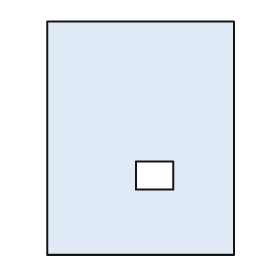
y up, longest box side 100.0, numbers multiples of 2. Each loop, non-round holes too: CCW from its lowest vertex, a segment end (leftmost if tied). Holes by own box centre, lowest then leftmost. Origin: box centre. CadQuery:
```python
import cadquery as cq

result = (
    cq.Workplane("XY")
    .moveTo(-40.0, -50.0)
    .lineTo(40.0, -50.0)
    .lineTo(40.0, 50.0)
    .lineTo(-40.0, 50.0)
    .close()
    .moveTo(-2.0, -22.0)
    .lineTo(14.0, -22.0)
    .lineTo(14.0, -10.0)
    .lineTo(-2.0, -10.0)
    .close()
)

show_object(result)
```